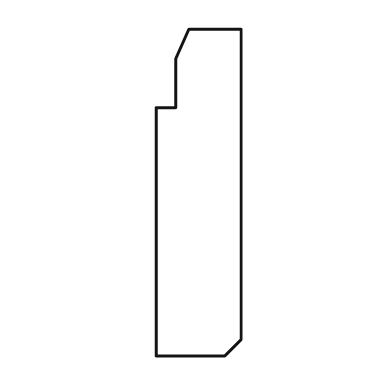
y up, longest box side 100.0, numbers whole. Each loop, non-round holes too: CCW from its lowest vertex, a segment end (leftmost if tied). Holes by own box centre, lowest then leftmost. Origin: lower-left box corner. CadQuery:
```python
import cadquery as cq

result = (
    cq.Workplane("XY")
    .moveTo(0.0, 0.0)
    .lineTo(21.0, 0.0)
    .lineTo(26.0, 5.0)
    .lineTo(26.0, 100.0)
    .lineTo(10.0, 100.0)
    .lineTo(6.0, 91.0)
    .lineTo(6.0, 76.0)
    .lineTo(0.0, 76.0)
    .close()
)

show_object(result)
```